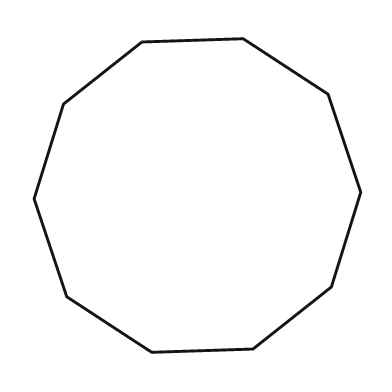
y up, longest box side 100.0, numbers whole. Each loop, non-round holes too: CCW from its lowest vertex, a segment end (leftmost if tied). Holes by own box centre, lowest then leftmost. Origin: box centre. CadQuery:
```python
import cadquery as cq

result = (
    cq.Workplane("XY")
    .moveTo(-14.0, -48.0)
    .lineTo(17.0, -47.0)
    .lineTo(41.0, -28.0)
    .lineTo(50.0, 1.0)
    .lineTo(40.0, 31.0)
    .lineTo(14.0, 48.0)
    .lineTo(-17.0, 47.0)
    .lineTo(-41.0, 28.0)
    .lineTo(-50.0, -1.0)
    .lineTo(-40.0, -31.0)
    .close()
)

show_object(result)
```